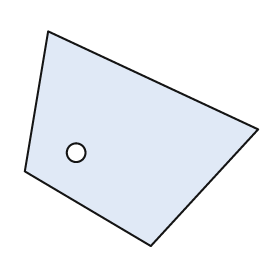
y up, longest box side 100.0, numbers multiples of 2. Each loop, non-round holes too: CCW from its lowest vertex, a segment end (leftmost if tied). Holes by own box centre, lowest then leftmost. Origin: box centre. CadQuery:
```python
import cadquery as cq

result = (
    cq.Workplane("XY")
    .moveTo(4.0, -46.0)
    .lineTo(50.0, 4.0)
    .lineTo(-40.0, 46.0)
    .lineTo(-50.0, -14.0)
    .close()
    .moveTo(-28.0, -6.0)
    .circle(4.0)
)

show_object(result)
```